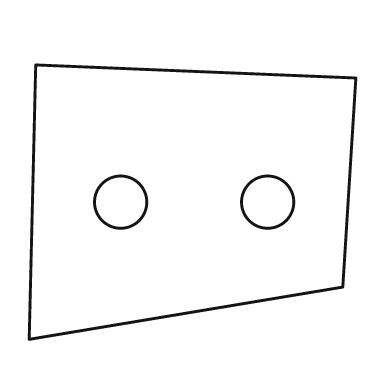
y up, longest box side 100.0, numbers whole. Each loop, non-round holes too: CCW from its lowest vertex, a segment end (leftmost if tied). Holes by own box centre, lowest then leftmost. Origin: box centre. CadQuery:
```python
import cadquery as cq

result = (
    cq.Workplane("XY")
    .moveTo(-50.0, -42.0)
    .lineTo(46.0, -26.0)
    .lineTo(50.0, 38.0)
    .lineTo(-48.0, 42.0)
    .close()
    .moveTo(-22.0, 0.0)
    .circle(8.0)
    .moveTo(23.0, 0.0)
    .circle(8.0)
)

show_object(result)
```